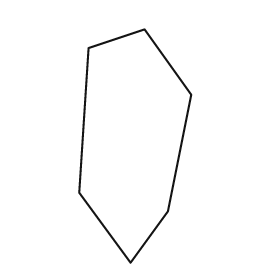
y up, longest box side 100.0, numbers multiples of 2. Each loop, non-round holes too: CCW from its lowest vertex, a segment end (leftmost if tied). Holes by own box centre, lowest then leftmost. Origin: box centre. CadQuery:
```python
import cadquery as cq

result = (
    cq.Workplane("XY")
    .moveTo(-2.0, -50.0)
    .lineTo(14.0, -28.0)
    .lineTo(24.0, 22.0)
    .lineTo(4.0, 50.0)
    .lineTo(-20.0, 42.0)
    .lineTo(-24.0, -20.0)
    .close()
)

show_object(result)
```